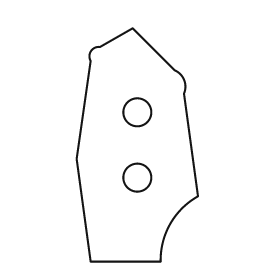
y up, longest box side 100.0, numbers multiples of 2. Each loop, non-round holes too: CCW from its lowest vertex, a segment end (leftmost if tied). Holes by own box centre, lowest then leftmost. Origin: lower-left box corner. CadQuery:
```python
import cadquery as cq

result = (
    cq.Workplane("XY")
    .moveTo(6.0, 0.0)
    .lineTo(36.0, 0.0)
    .threePointArc((40.0, 16.0), (52.0, 28.0))
    .lineTo(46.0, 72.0)
    .threePointArc((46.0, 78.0), (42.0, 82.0))
    .lineTo(24.0, 100.0)
    .lineTo(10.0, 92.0)
    .threePointArc((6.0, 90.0), (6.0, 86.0))
    .lineTo(0.0, 44.0)
    .close()
    .moveTo(26.0, 36.0)
    .circle(6.0)
    .moveTo(26.0, 64.0)
    .circle(6.0)
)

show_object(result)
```